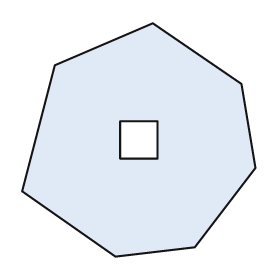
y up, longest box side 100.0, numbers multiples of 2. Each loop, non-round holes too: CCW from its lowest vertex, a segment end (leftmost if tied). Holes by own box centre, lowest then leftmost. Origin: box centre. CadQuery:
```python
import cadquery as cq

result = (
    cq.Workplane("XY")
    .moveTo(-10.0, -50.0)
    .lineTo(24.0, -46.0)
    .lineTo(50.0, -12.0)
    .lineTo(44.0, 24.0)
    .lineTo(6.0, 50.0)
    .lineTo(-36.0, 32.0)
    .lineTo(-50.0, -22.0)
    .close()
    .moveTo(-8.0, -8.0)
    .lineTo(8.0, -8.0)
    .lineTo(8.0, 8.0)
    .lineTo(-8.0, 8.0)
    .close()
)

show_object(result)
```